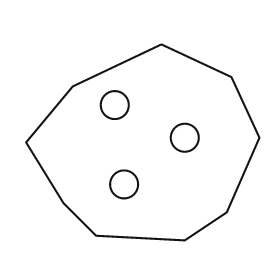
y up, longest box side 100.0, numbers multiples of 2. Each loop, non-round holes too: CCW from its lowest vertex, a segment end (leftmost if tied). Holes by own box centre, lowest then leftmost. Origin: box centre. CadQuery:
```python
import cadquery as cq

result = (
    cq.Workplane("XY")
    .moveTo(18.0, -42.0)
    .lineTo(36.0, -30.0)
    .lineTo(50.0, 2.0)
    .lineTo(38.0, 28.0)
    .lineTo(8.0, 42.0)
    .lineTo(-30.0, 24.0)
    .lineTo(-50.0, 0.0)
    .lineTo(-34.0, -26.0)
    .lineTo(-20.0, -40.0)
    .close()
    .moveTo(-8.0, -18.0)
    .circle(6.0)
    .moveTo(18.0, 2.0)
    .circle(6.0)
    .moveTo(-12.0, 16.0)
    .circle(6.0)
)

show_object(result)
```